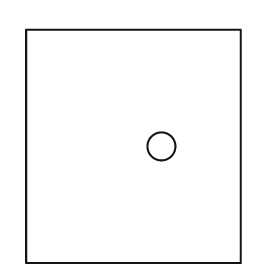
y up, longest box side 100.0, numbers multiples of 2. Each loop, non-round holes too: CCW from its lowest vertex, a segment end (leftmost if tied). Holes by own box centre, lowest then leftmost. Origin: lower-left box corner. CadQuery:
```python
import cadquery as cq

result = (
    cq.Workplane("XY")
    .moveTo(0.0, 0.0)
    .lineTo(92.0, 0.0)
    .lineTo(92.0, 100.0)
    .lineTo(0.0, 100.0)
    .close()
    .moveTo(58.0, 50.0)
    .circle(6.0)
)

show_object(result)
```